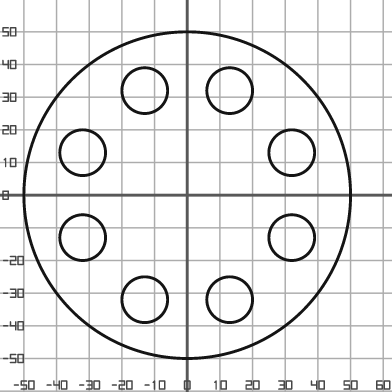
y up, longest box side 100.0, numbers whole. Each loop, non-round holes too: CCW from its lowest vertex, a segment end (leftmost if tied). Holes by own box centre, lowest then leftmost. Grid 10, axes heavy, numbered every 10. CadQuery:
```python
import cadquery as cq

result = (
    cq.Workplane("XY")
    .moveTo(0.0, 0.0)
    .circle(50.0)
    .moveTo(-13.0, -32.0)
    .circle(7.0)
    .moveTo(13.0, -32.0)
    .circle(7.0)
    .moveTo(-32.0, -13.0)
    .circle(7.0)
    .moveTo(32.0, -13.0)
    .circle(7.0)
    .moveTo(-32.0, 13.0)
    .circle(7.0)
    .moveTo(32.0, 13.0)
    .circle(7.0)
    .moveTo(-13.0, 32.0)
    .circle(7.0)
    .moveTo(13.0, 32.0)
    .circle(7.0)
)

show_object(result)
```